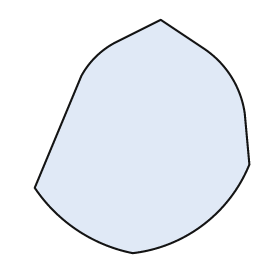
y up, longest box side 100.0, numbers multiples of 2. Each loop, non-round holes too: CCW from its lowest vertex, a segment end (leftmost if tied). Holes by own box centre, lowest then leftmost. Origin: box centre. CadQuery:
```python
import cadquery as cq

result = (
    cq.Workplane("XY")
    .moveTo(-4.0, -50.0)
    .threePointArc((26.0, -38.0), (46.0, -12.0))
    .lineTo(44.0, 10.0)
    .threePointArc((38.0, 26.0), (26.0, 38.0))
    .lineTo(8.0, 50.0)
    .lineTo(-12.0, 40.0)
    .threePointArc((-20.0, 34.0), (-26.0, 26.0))
    .lineTo(-46.0, -22.0)
    .threePointArc((-28.0, -40.0), (-4.0, -50.0))
    .close()
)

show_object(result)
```